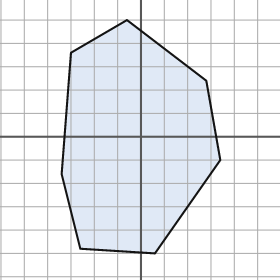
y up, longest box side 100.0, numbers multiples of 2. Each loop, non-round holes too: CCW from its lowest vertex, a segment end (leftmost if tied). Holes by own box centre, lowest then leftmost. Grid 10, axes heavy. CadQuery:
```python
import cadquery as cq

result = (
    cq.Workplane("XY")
    .moveTo(6.0, -50.0)
    .lineTo(34.0, -10.0)
    .lineTo(28.0, 24.0)
    .lineTo(-6.0, 50.0)
    .lineTo(-30.0, 36.0)
    .lineTo(-34.0, -16.0)
    .lineTo(-26.0, -48.0)
    .close()
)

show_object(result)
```